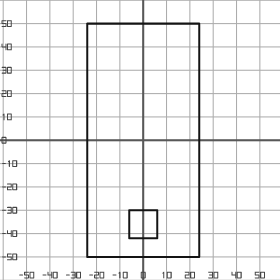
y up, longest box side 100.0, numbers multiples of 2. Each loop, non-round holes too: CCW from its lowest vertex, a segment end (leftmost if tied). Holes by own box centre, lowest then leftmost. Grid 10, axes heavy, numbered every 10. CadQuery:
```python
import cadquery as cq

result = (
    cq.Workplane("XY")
    .moveTo(-24.0, -50.0)
    .lineTo(24.0, -50.0)
    .lineTo(24.0, 50.0)
    .lineTo(-24.0, 50.0)
    .close()
    .moveTo(-6.0, -42.0)
    .lineTo(6.0, -42.0)
    .lineTo(6.0, -30.0)
    .lineTo(-6.0, -30.0)
    .close()
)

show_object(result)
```